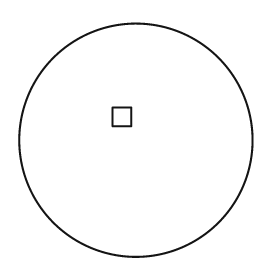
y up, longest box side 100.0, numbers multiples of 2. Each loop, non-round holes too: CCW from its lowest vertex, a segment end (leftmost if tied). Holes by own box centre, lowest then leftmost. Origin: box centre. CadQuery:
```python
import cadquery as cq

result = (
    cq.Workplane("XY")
    .moveTo(0.0, 0.0)
    .circle(50.0)
    .moveTo(-10.0, 6.0)
    .lineTo(-2.0, 6.0)
    .lineTo(-2.0, 14.0)
    .lineTo(-10.0, 14.0)
    .close()
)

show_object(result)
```